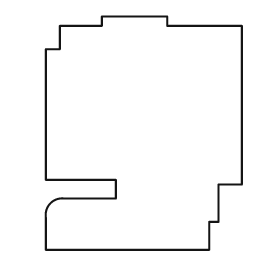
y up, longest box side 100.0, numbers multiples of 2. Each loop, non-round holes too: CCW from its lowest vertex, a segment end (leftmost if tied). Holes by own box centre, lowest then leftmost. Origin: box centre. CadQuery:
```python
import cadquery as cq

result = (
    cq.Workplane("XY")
    .moveTo(-42.0, -50.0)
    .lineTo(28.0, -50.0)
    .lineTo(28.0, -38.0)
    .lineTo(32.0, -38.0)
    .lineTo(32.0, -22.0)
    .lineTo(42.0, -22.0)
    .lineTo(42.0, 46.0)
    .lineTo(10.0, 46.0)
    .lineTo(10.0, 50.0)
    .lineTo(-18.0, 50.0)
    .lineTo(-18.0, 46.0)
    .lineTo(-36.0, 46.0)
    .lineTo(-36.0, 36.0)
    .lineTo(-42.0, 36.0)
    .lineTo(-42.0, -20.0)
    .lineTo(-12.0, -20.0)
    .lineTo(-12.0, -28.0)
    .lineTo(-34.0, -28.0)
    .threePointArc((-40.0, -30.0), (-42.0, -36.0))
    .close()
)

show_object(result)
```